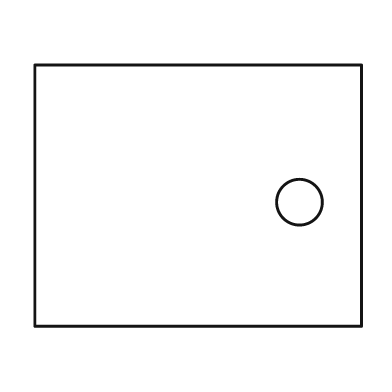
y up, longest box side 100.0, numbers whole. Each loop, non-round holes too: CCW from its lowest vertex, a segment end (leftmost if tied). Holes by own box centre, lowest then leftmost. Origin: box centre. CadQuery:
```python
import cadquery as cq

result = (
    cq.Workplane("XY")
    .moveTo(-50.0, -40.0)
    .lineTo(50.0, -40.0)
    .lineTo(50.0, 40.0)
    .lineTo(-50.0, 40.0)
    .close()
    .moveTo(31.0, -2.0)
    .circle(7.0)
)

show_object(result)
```